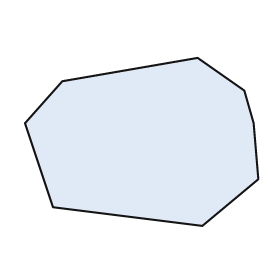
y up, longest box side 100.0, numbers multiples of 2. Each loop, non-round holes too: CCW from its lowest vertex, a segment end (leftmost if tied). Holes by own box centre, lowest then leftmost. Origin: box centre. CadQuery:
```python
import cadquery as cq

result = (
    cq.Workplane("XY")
    .moveTo(26.0, -36.0)
    .lineTo(50.0, -16.0)
    .lineTo(48.0, 8.0)
    .lineTo(44.0, 22.0)
    .lineTo(24.0, 36.0)
    .lineTo(-34.0, 26.0)
    .lineTo(-50.0, 8.0)
    .lineTo(-38.0, -28.0)
    .close()
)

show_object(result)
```